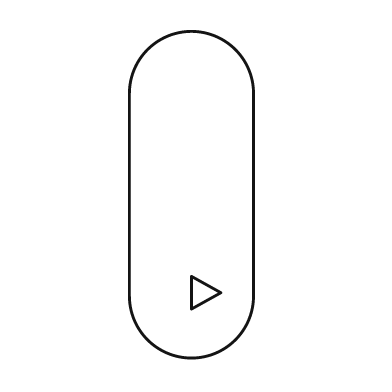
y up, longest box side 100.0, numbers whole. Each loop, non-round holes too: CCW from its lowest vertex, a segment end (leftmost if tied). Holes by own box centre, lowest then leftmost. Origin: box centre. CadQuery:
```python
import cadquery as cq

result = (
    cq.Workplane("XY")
    .moveTo(-19.0, -31.0)
    .threePointArc((0.0, -50.0), (19.0, -31.0))
    .lineTo(19.0, 31.0)
    .threePointArc((0.0, 50.0), (-19.0, 31.0))
    .close()
    .moveTo(0.0, -35.0)
    .lineTo(9.0, -30.0)
    .lineTo(0.0, -25.0)
    .close()
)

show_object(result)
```